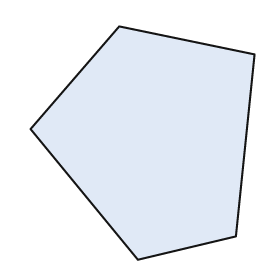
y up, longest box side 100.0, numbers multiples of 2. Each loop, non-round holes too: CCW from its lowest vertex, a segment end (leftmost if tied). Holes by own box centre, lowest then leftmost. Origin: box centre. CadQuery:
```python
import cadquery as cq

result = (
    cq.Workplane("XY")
    .moveTo(-2.0, -50.0)
    .lineTo(40.0, -40.0)
    .lineTo(48.0, 38.0)
    .lineTo(-10.0, 50.0)
    .lineTo(-48.0, 6.0)
    .close()
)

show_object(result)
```